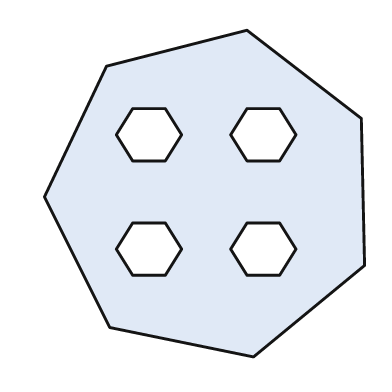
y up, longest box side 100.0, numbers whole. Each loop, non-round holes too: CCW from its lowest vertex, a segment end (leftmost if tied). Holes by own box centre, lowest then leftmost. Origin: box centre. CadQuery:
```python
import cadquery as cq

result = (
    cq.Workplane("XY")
    .moveTo(15.0, -50.0)
    .lineTo(49.0, -22.0)
    .lineTo(48.0, 23.0)
    .lineTo(13.0, 50.0)
    .lineTo(-30.0, 39.0)
    .lineTo(-49.0, -1.0)
    .lineTo(-29.0, -41.0)
    .close()
    .moveTo(-22.0, -25.0)
    .lineTo(-12.0, -25.0)
    .lineTo(-7.0, -17.0)
    .lineTo(-12.0, -9.0)
    .lineTo(-22.0, -9.0)
    .lineTo(-27.0, -17.0)
    .close()
    .moveTo(13.0, -25.0)
    .lineTo(23.0, -25.0)
    .lineTo(28.0, -17.0)
    .lineTo(23.0, -9.0)
    .lineTo(13.0, -9.0)
    .lineTo(8.0, -17.0)
    .close()
    .moveTo(-22.0, 10.0)
    .lineTo(-12.0, 10.0)
    .lineTo(-7.0, 18.0)
    .lineTo(-12.0, 26.0)
    .lineTo(-22.0, 26.0)
    .lineTo(-27.0, 18.0)
    .close()
    .moveTo(13.0, 10.0)
    .lineTo(23.0, 10.0)
    .lineTo(28.0, 18.0)
    .lineTo(23.0, 26.0)
    .lineTo(13.0, 26.0)
    .lineTo(8.0, 18.0)
    .close()
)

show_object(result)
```